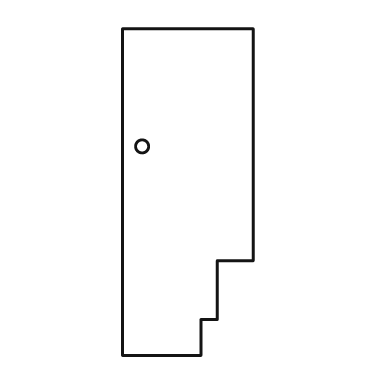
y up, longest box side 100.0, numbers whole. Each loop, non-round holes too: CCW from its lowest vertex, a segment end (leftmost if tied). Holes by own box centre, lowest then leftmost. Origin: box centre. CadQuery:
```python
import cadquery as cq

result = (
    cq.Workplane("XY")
    .moveTo(-20.0, -50.0)
    .lineTo(4.0, -50.0)
    .lineTo(4.0, -39.0)
    .lineTo(9.0, -39.0)
    .lineTo(9.0, -21.0)
    .lineTo(20.0, -21.0)
    .lineTo(20.0, 50.0)
    .lineTo(-20.0, 50.0)
    .close()
    .moveTo(-14.0, 14.0)
    .circle(2.0)
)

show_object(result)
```